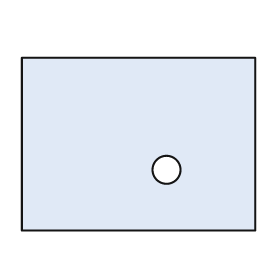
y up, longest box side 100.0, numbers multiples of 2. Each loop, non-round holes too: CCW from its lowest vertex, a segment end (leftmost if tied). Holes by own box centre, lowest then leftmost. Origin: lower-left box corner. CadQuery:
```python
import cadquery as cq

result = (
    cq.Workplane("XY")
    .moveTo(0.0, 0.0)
    .lineTo(100.0, 0.0)
    .lineTo(100.0, 74.0)
    .lineTo(0.0, 74.0)
    .close()
    .moveTo(62.0, 26.0)
    .circle(6.0)
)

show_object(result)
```